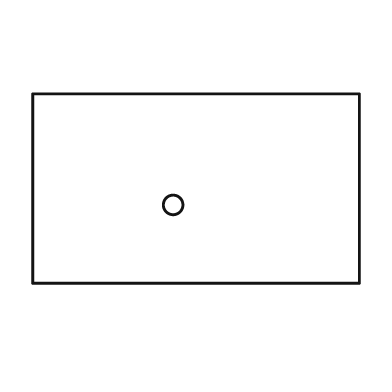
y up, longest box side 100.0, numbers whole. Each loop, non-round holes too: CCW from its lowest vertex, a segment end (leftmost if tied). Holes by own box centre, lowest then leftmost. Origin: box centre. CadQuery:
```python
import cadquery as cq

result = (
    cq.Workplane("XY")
    .moveTo(-50.0, -29.0)
    .lineTo(50.0, -29.0)
    .lineTo(50.0, 29.0)
    .lineTo(-50.0, 29.0)
    .close()
    .moveTo(-7.0, -5.0)
    .circle(3.0)
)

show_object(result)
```